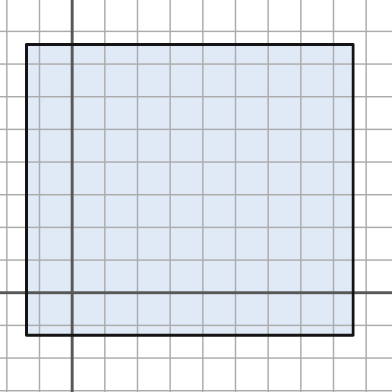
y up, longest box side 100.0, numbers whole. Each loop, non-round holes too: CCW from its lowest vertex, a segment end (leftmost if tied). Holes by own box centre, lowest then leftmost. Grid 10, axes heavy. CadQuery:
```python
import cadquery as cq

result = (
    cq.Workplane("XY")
    .moveTo(-14.0, -13.0)
    .lineTo(86.0, -13.0)
    .lineTo(86.0, 76.0)
    .lineTo(-14.0, 76.0)
    .close()
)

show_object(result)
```